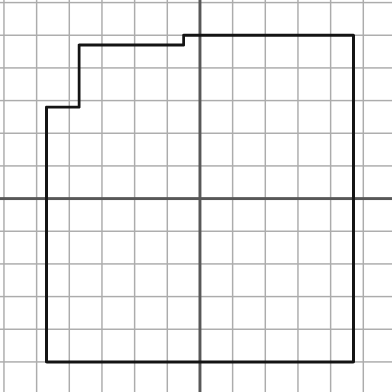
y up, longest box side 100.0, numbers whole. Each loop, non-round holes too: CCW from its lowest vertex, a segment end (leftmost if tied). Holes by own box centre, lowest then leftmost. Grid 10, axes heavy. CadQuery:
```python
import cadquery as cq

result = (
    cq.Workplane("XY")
    .moveTo(-47.0, -50.0)
    .lineTo(47.0, -50.0)
    .lineTo(47.0, 50.0)
    .lineTo(-5.0, 50.0)
    .lineTo(-5.0, 47.0)
    .lineTo(-37.0, 47.0)
    .lineTo(-37.0, 28.0)
    .lineTo(-47.0, 28.0)
    .close()
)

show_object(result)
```